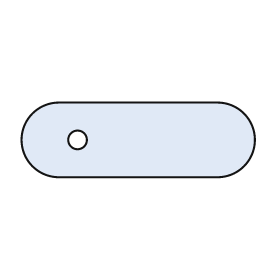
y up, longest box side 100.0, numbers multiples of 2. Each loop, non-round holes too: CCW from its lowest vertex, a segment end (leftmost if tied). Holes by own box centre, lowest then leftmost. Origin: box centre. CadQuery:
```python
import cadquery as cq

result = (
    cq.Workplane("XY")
    .moveTo(-34.0, -16.0)
    .lineTo(34.0, -16.0)
    .threePointArc((50.0, 0.0), (34.0, 16.0))
    .lineTo(-34.0, 16.0)
    .threePointArc((-50.0, 0.0), (-34.0, -16.0))
    .close()
    .moveTo(-26.0, 0.0)
    .circle(4.0)
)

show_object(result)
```